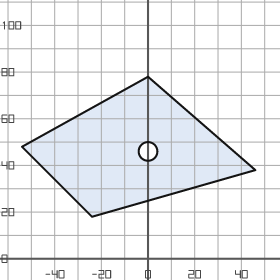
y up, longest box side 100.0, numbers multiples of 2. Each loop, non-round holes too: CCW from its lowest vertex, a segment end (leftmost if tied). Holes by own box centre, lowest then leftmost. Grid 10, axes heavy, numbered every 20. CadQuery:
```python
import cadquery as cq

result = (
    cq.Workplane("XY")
    .moveTo(-24.0, 18.0)
    .lineTo(46.0, 38.0)
    .lineTo(0.0, 78.0)
    .lineTo(-54.0, 48.0)
    .close()
    .moveTo(0.0, 46.0)
    .circle(4.0)
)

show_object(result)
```